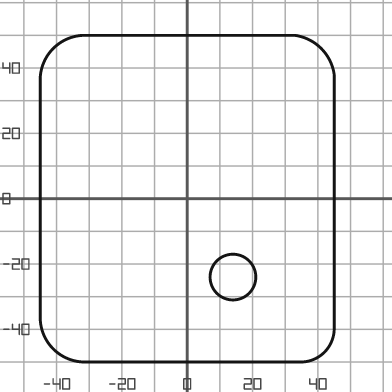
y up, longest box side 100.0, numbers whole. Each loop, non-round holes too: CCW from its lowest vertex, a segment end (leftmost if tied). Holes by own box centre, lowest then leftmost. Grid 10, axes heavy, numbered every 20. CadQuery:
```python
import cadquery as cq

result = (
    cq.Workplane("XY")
    .moveTo(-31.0, -50.0)
    .lineTo(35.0, -50.0)
    .threePointArc((42.0, -47.0), (45.0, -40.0))
    .lineTo(45.0, 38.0)
    .threePointArc((41.0, 46.0), (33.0, 50.0))
    .lineTo(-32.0, 50.0)
    .threePointArc((-41.0, 46.0), (-45.0, 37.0))
    .lineTo(-45.0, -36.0)
    .threePointArc((-41.0, -46.0), (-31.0, -50.0))
    .close()
    .moveTo(14.0, -24.0)
    .circle(7.0)
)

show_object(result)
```